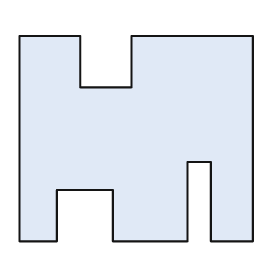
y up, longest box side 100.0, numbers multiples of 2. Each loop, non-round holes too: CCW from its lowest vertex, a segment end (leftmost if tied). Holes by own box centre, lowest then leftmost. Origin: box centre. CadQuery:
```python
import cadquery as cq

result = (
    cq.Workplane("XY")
    .moveTo(-50.0, -44.0)
    .lineTo(-34.0, -44.0)
    .lineTo(-34.0, -22.0)
    .lineTo(-10.0, -22.0)
    .lineTo(-10.0, -44.0)
    .lineTo(22.0, -44.0)
    .lineTo(22.0, -10.0)
    .lineTo(32.0, -10.0)
    .lineTo(32.0, -44.0)
    .lineTo(50.0, -44.0)
    .lineTo(50.0, 44.0)
    .lineTo(-2.0, 44.0)
    .lineTo(-2.0, 22.0)
    .lineTo(-24.0, 22.0)
    .lineTo(-24.0, 44.0)
    .lineTo(-50.0, 44.0)
    .close()
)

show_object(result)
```